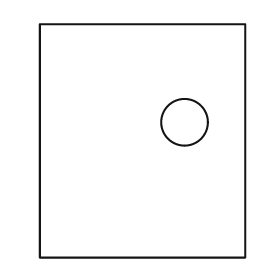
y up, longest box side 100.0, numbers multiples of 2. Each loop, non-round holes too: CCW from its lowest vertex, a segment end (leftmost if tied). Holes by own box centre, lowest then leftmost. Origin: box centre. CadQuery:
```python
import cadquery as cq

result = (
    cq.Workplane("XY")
    .moveTo(-44.0, -50.0)
    .lineTo(44.0, -50.0)
    .lineTo(44.0, 50.0)
    .lineTo(-44.0, 50.0)
    .close()
    .moveTo(18.0, 8.0)
    .circle(10.0)
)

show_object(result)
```